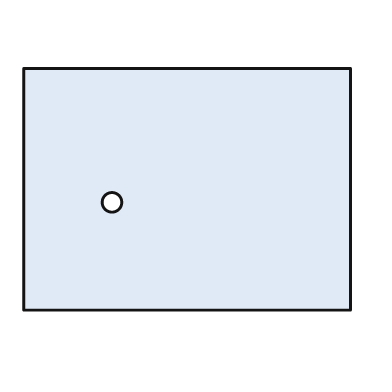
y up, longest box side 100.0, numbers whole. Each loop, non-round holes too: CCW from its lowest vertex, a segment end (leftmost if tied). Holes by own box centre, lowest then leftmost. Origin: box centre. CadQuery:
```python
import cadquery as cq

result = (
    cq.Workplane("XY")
    .moveTo(-50.0, -37.0)
    .lineTo(50.0, -37.0)
    .lineTo(50.0, 37.0)
    .lineTo(-50.0, 37.0)
    .close()
    .moveTo(-23.0, -4.0)
    .circle(3.0)
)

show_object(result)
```